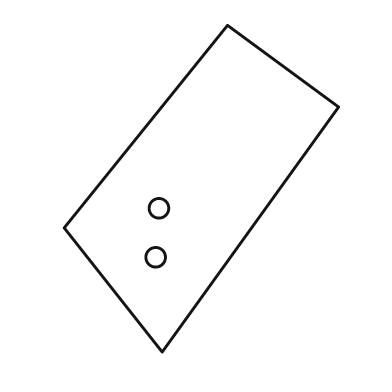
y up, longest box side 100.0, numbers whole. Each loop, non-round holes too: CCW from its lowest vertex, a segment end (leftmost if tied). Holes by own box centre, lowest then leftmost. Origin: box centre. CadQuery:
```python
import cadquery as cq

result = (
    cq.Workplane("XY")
    .moveTo(-12.0, -50.0)
    .lineTo(42.0, 25.0)
    .lineTo(8.0, 50.0)
    .lineTo(-42.0, -12.0)
    .close()
    .moveTo(-14.0, -21.0)
    .circle(3.0)
    .moveTo(-13.0, -6.0)
    .circle(3.0)
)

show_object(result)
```